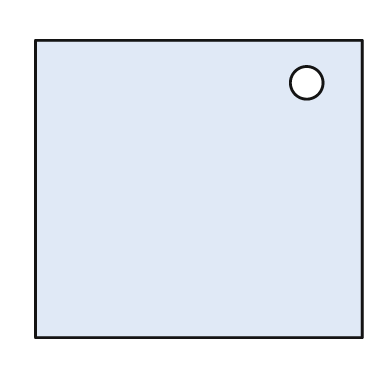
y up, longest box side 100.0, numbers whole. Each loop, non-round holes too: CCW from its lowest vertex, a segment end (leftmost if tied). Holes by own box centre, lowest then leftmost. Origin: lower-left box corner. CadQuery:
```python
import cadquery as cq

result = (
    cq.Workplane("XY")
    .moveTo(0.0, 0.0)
    .lineTo(100.0, 0.0)
    .lineTo(100.0, 91.0)
    .lineTo(0.0, 91.0)
    .close()
    .moveTo(83.0, 78.0)
    .circle(5.0)
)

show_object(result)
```